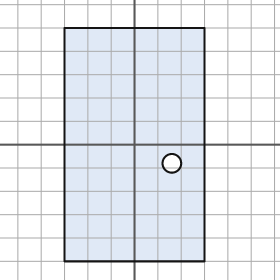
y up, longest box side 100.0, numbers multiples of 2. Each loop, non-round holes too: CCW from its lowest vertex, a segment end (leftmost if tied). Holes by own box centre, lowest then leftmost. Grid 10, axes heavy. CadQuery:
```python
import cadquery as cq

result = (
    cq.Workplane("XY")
    .moveTo(-30.0, -50.0)
    .lineTo(30.0, -50.0)
    .lineTo(30.0, 50.0)
    .lineTo(-30.0, 50.0)
    .close()
    .moveTo(16.0, -8.0)
    .circle(4.0)
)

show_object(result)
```